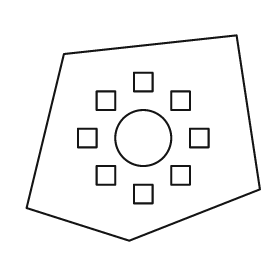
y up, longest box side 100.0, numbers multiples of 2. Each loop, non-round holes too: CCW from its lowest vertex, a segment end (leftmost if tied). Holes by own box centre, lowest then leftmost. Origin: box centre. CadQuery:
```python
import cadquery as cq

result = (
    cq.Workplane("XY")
    .moveTo(-6.0, -44.0)
    .lineTo(50.0, -22.0)
    .lineTo(40.0, 44.0)
    .lineTo(-34.0, 36.0)
    .lineTo(-50.0, -30.0)
    .close()
    .moveTo(-4.0, -28.0)
    .lineTo(4.0, -28.0)
    .lineTo(4.0, -20.0)
    .lineTo(-4.0, -20.0)
    .close()
    .moveTo(-20.0, -20.0)
    .lineTo(-12.0, -20.0)
    .lineTo(-12.0, -12.0)
    .lineTo(-20.0, -12.0)
    .close()
    .moveTo(12.0, -20.0)
    .lineTo(20.0, -20.0)
    .lineTo(20.0, -12.0)
    .lineTo(12.0, -12.0)
    .close()
    .moveTo(-28.0, -4.0)
    .lineTo(-20.0, -4.0)
    .lineTo(-20.0, 4.0)
    .lineTo(-28.0, 4.0)
    .close()
    .moveTo(0.0, 0.0)
    .circle(12.0)
    .moveTo(20.0, -4.0)
    .lineTo(28.0, -4.0)
    .lineTo(28.0, 4.0)
    .lineTo(20.0, 4.0)
    .close()
    .moveTo(-20.0, 12.0)
    .lineTo(-12.0, 12.0)
    .lineTo(-12.0, 20.0)
    .lineTo(-20.0, 20.0)
    .close()
    .moveTo(12.0, 12.0)
    .lineTo(20.0, 12.0)
    .lineTo(20.0, 20.0)
    .lineTo(12.0, 20.0)
    .close()
    .moveTo(-4.0, 20.0)
    .lineTo(4.0, 20.0)
    .lineTo(4.0, 28.0)
    .lineTo(-4.0, 28.0)
    .close()
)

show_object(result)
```